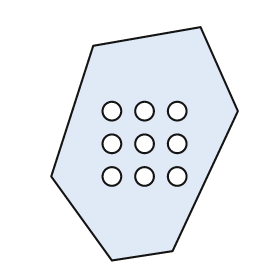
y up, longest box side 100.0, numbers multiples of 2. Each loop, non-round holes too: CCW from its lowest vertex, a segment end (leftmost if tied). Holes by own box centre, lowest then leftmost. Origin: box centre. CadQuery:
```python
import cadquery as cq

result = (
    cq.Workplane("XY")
    .moveTo(-14.0, -50.0)
    .lineTo(12.0, -46.0)
    .lineTo(40.0, 14.0)
    .lineTo(24.0, 50.0)
    .lineTo(-22.0, 42.0)
    .lineTo(-40.0, -14.0)
    .close()
    .moveTo(-14.0, -14.0)
    .circle(4.0)
    .moveTo(0.0, -14.0)
    .circle(4.0)
    .moveTo(14.0, -14.0)
    .circle(4.0)
    .moveTo(-14.0, 0.0)
    .circle(4.0)
    .moveTo(0.0, 0.0)
    .circle(4.0)
    .moveTo(14.0, 0.0)
    .circle(4.0)
    .moveTo(-14.0, 14.0)
    .circle(4.0)
    .moveTo(0.0, 14.0)
    .circle(4.0)
    .moveTo(14.0, 14.0)
    .circle(4.0)
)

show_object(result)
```